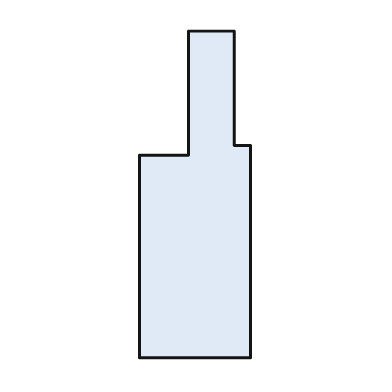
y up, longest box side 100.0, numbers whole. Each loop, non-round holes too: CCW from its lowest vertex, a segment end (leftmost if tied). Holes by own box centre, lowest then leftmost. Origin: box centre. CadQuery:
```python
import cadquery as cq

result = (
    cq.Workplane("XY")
    .moveTo(-17.0, -50.0)
    .lineTo(17.0, -50.0)
    .lineTo(17.0, 15.0)
    .lineTo(12.0, 15.0)
    .lineTo(12.0, 50.0)
    .lineTo(-2.0, 50.0)
    .lineTo(-2.0, 12.0)
    .lineTo(-17.0, 12.0)
    .close()
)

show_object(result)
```